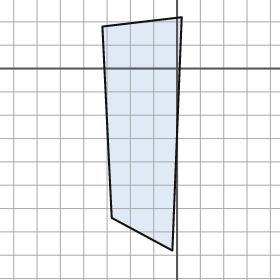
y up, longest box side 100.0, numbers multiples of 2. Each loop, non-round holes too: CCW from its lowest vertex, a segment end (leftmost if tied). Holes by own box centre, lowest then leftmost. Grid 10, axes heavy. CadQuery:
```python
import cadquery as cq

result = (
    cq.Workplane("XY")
    .moveTo(-2.0, -78.0)
    .lineTo(2.0, 22.0)
    .lineTo(-32.0, 18.0)
    .lineTo(-28.0, -64.0)
    .close()
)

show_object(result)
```